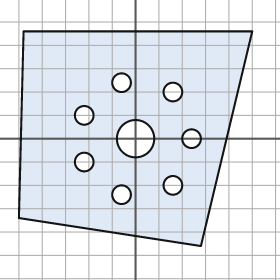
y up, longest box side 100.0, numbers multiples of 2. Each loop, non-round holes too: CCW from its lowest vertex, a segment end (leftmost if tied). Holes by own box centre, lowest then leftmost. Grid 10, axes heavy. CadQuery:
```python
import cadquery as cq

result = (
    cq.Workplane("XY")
    .moveTo(28.0, -46.0)
    .lineTo(50.0, 46.0)
    .lineTo(-48.0, 46.0)
    .lineTo(-50.0, -34.0)
    .close()
    .moveTo(-6.0, -24.0)
    .circle(4.0)
    .moveTo(16.0, -20.0)
    .circle(4.0)
    .moveTo(-22.0, -10.0)
    .circle(4.0)
    .moveTo(0.0, 0.0)
    .circle(8.0)
    .moveTo(24.0, 0.0)
    .circle(4.0)
    .moveTo(-22.0, 10.0)
    .circle(4.0)
    .moveTo(16.0, 20.0)
    .circle(4.0)
    .moveTo(-6.0, 24.0)
    .circle(4.0)
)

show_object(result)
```